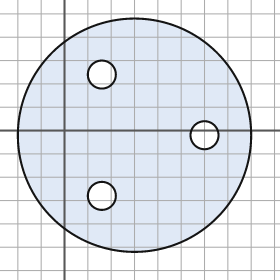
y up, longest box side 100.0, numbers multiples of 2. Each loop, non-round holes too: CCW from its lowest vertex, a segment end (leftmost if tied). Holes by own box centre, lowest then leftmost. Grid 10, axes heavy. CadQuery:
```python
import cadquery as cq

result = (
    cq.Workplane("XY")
    .moveTo(30.0, -2.0)
    .circle(50.0)
    .moveTo(16.0, -28.0)
    .circle(6.0)
    .moveTo(60.0, -2.0)
    .circle(6.0)
    .moveTo(16.0, 24.0)
    .circle(6.0)
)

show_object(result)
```